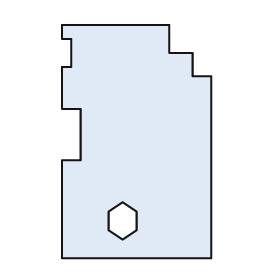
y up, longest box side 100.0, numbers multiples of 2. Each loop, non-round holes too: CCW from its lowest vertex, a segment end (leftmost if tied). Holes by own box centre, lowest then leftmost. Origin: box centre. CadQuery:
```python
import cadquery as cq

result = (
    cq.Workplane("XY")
    .moveTo(-32.0, -50.0)
    .lineTo(32.0, -50.0)
    .lineTo(32.0, 28.0)
    .lineTo(24.0, 28.0)
    .lineTo(24.0, 38.0)
    .lineTo(14.0, 38.0)
    .lineTo(14.0, 50.0)
    .lineTo(-32.0, 50.0)
    .lineTo(-32.0, 44.0)
    .lineTo(-28.0, 44.0)
    .lineTo(-28.0, 32.0)
    .lineTo(-32.0, 32.0)
    .lineTo(-32.0, 14.0)
    .lineTo(-24.0, 14.0)
    .lineTo(-24.0, -8.0)
    .lineTo(-32.0, -8.0)
    .close()
    .moveTo(-6.0, -42.0)
    .lineTo(0.0, -38.0)
    .lineTo(0.0, -30.0)
    .lineTo(-6.0, -26.0)
    .lineTo(-12.0, -30.0)
    .lineTo(-12.0, -38.0)
    .close()
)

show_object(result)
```